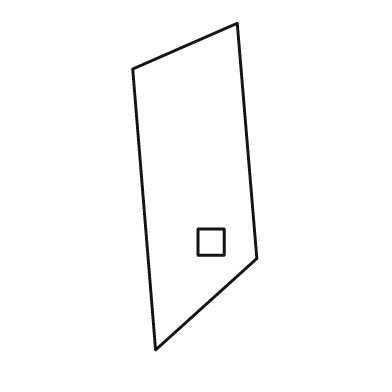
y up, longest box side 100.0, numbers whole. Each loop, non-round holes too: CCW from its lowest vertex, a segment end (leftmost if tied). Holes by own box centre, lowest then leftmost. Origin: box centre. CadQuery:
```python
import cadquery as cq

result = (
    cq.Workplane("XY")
    .moveTo(-12.0, -50.0)
    .lineTo(19.0, -22.0)
    .lineTo(13.0, 50.0)
    .lineTo(-19.0, 36.0)
    .close()
    .moveTo(1.0, -21.0)
    .lineTo(9.0, -21.0)
    .lineTo(9.0, -13.0)
    .lineTo(1.0, -13.0)
    .close()
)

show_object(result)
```